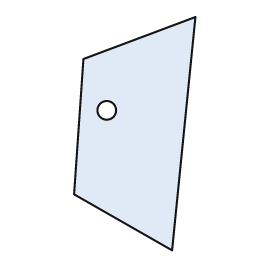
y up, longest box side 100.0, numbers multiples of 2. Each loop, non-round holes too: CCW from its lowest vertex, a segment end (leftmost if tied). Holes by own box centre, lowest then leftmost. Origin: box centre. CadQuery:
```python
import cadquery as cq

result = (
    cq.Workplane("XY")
    .moveTo(16.0, -50.0)
    .lineTo(26.0, 50.0)
    .lineTo(-22.0, 32.0)
    .lineTo(-26.0, -26.0)
    .close()
    .moveTo(-12.0, 10.0)
    .circle(4.0)
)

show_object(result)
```